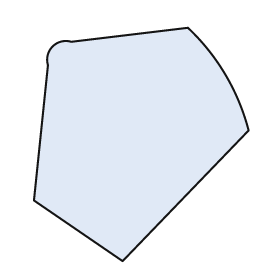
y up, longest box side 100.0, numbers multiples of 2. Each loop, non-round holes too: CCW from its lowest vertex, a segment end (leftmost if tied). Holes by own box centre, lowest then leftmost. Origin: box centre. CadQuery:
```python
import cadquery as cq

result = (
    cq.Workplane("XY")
    .moveTo(-8.0, -50.0)
    .lineTo(46.0, 6.0)
    .threePointArc((36.0, 30.0), (20.0, 50.0))
    .lineTo(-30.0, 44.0)
    .threePointArc((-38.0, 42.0), (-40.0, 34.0))
    .lineTo(-46.0, -24.0)
    .close()
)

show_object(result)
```